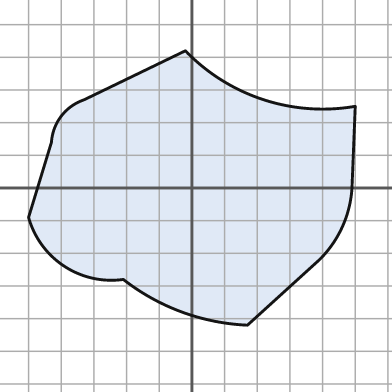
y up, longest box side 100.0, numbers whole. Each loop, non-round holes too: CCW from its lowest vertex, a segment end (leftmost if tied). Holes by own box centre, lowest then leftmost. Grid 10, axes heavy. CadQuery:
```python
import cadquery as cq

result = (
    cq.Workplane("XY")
    .moveTo(17.0, -42.0)
    .lineTo(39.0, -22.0)
    .threePointArc((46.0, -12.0), (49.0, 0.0))
    .lineTo(50.0, 25.0)
    .threePointArc((22.0, 27.0), (-2.0, 42.0))
    .lineTo(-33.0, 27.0)
    .threePointArc((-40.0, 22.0), (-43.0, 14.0))
    .lineTo(-50.0, -9.0)
    .threePointArc((-39.0, -24.0), (-21.0, -28.0))
    .threePointArc((-3.0, -38.0), (17.0, -42.0))
    .close()
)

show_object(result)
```